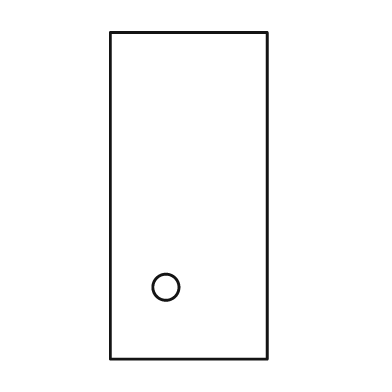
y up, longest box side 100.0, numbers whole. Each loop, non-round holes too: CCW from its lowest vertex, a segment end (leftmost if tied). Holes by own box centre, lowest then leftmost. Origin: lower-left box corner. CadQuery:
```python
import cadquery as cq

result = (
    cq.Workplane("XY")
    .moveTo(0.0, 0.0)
    .lineTo(48.0, 0.0)
    .lineTo(48.0, 100.0)
    .lineTo(0.0, 100.0)
    .close()
    .moveTo(17.0, 22.0)
    .circle(4.0)
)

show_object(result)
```